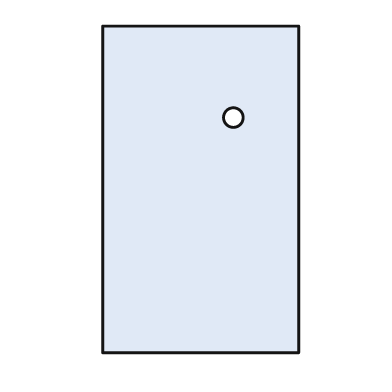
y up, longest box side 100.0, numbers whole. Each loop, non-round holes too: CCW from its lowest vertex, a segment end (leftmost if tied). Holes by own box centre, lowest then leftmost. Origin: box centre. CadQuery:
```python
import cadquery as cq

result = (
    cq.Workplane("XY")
    .moveTo(-30.0, -50.0)
    .lineTo(30.0, -50.0)
    .lineTo(30.0, 50.0)
    .lineTo(-30.0, 50.0)
    .close()
    .moveTo(10.0, 22.0)
    .circle(3.0)
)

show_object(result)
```